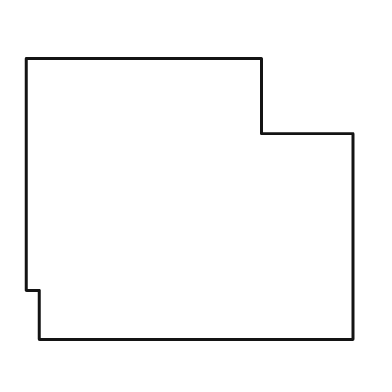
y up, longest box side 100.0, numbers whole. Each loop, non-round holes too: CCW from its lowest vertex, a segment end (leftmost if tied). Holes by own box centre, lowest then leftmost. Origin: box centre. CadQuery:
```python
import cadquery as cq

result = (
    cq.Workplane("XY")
    .moveTo(-46.0, -43.0)
    .lineTo(50.0, -43.0)
    .lineTo(50.0, 20.0)
    .lineTo(22.0, 20.0)
    .lineTo(22.0, 43.0)
    .lineTo(-50.0, 43.0)
    .lineTo(-50.0, -28.0)
    .lineTo(-46.0, -28.0)
    .close()
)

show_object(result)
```